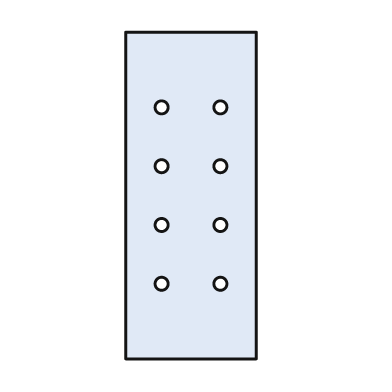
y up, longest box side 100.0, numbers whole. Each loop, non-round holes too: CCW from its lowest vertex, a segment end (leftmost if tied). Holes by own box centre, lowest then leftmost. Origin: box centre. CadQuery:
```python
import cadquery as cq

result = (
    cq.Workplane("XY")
    .moveTo(-20.0, -50.0)
    .lineTo(20.0, -50.0)
    .lineTo(20.0, 50.0)
    .lineTo(-20.0, 50.0)
    .close()
    .moveTo(-9.0, -27.0)
    .circle(2.0)
    .moveTo(9.0, -27.0)
    .circle(2.0)
    .moveTo(-9.0, -9.0)
    .circle(2.0)
    .moveTo(9.0, -9.0)
    .circle(2.0)
    .moveTo(-9.0, 9.0)
    .circle(2.0)
    .moveTo(9.0, 9.0)
    .circle(2.0)
    .moveTo(-9.0, 27.0)
    .circle(2.0)
    .moveTo(9.0, 27.0)
    .circle(2.0)
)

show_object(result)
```